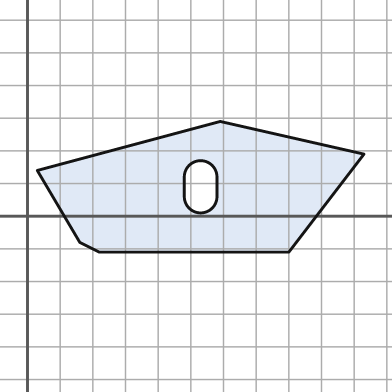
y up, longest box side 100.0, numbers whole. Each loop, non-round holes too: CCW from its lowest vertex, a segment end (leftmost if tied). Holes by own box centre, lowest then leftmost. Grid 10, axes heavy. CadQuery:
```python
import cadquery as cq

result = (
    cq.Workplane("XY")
    .moveTo(22.0, -11.0)
    .lineTo(80.0, -11.0)
    .lineTo(103.0, 19.0)
    .lineTo(59.0, 29.0)
    .lineTo(3.0, 14.0)
    .lineTo(16.0, -8.0)
    .close()
    .moveTo(48.0, 6.0)
    .threePointArc((53.0, 1.0), (58.0, 6.0))
    .lineTo(58.0, 12.0)
    .threePointArc((53.0, 17.0), (48.0, 12.0))
    .close()
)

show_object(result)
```